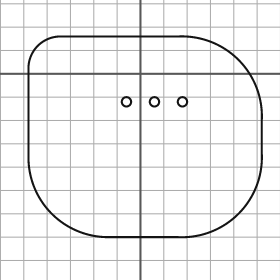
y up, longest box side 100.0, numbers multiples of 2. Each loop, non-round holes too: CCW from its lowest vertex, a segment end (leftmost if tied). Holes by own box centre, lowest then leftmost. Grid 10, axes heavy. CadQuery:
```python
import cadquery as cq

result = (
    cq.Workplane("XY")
    .moveTo(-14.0, -70.0)
    .lineTo(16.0, -70.0)
    .threePointArc((42.0, -60.0), (52.0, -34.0))
    .lineTo(52.0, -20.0)
    .threePointArc((42.0, 6.0), (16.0, 16.0))
    .lineTo(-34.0, 16.0)
    .threePointArc((-44.0, 12.0), (-48.0, 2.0))
    .lineTo(-48.0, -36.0)
    .threePointArc((-38.0, -60.0), (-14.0, -70.0))
    .close()
    .moveTo(-6.0, -12.0)
    .circle(2.0)
    .moveTo(6.0, -12.0)
    .circle(2.0)
    .moveTo(18.0, -12.0)
    .circle(2.0)
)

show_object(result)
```